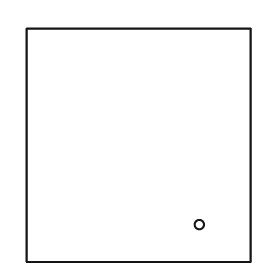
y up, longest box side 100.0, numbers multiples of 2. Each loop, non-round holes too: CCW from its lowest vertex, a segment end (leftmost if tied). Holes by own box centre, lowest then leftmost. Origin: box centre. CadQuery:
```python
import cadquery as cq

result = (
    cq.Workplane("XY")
    .moveTo(-48.0, -50.0)
    .lineTo(48.0, -50.0)
    .lineTo(48.0, 50.0)
    .lineTo(-48.0, 50.0)
    .close()
    .moveTo(26.0, -34.0)
    .circle(2.0)
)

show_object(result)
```